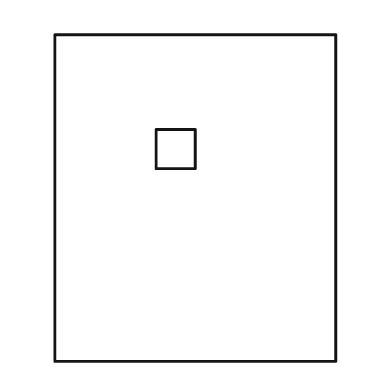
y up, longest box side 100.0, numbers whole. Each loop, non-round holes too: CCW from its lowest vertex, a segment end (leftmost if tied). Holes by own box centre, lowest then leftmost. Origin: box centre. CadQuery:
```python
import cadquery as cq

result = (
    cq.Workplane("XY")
    .moveTo(-43.0, -50.0)
    .lineTo(43.0, -50.0)
    .lineTo(43.0, 50.0)
    .lineTo(-43.0, 50.0)
    .close()
    .moveTo(-12.0, 9.0)
    .lineTo(0.0, 9.0)
    .lineTo(0.0, 21.0)
    .lineTo(-12.0, 21.0)
    .close()
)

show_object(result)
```